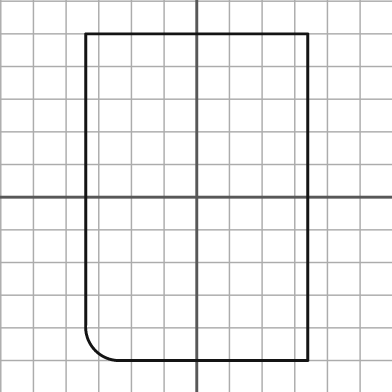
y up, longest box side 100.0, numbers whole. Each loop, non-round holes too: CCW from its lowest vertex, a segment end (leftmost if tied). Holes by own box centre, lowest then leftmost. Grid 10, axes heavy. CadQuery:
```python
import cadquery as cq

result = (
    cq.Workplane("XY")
    .moveTo(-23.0, -50.0)
    .lineTo(34.0, -50.0)
    .lineTo(34.0, 50.0)
    .lineTo(-34.0, 50.0)
    .lineTo(-34.0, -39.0)
    .threePointArc((-31.0, -47.0), (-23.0, -50.0))
    .close()
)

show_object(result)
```